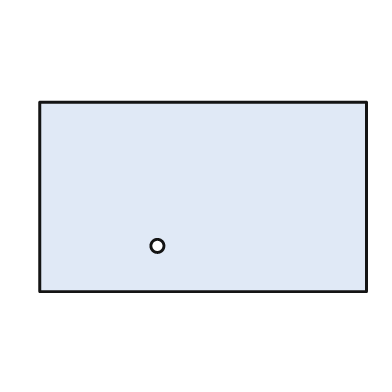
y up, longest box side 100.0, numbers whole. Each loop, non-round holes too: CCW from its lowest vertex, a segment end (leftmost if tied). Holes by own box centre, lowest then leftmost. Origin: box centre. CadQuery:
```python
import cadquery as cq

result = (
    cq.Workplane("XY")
    .moveTo(-50.0, -29.0)
    .lineTo(50.0, -29.0)
    .lineTo(50.0, 29.0)
    .lineTo(-50.0, 29.0)
    .close()
    .moveTo(-14.0, -15.0)
    .circle(2.0)
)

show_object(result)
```